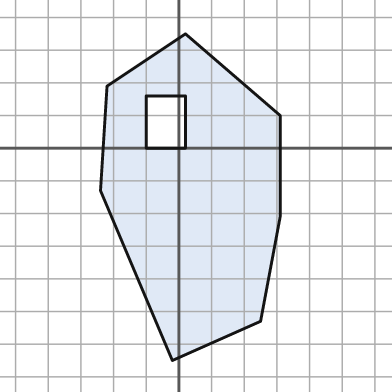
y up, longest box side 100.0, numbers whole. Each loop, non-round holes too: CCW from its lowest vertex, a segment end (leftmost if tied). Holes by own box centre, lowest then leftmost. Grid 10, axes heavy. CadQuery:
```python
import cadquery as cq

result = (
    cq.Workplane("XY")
    .moveTo(-2.0, -65.0)
    .lineTo(25.0, -53.0)
    .lineTo(31.0, -21.0)
    .lineTo(31.0, 10.0)
    .lineTo(2.0, 35.0)
    .lineTo(-22.0, 19.0)
    .lineTo(-24.0, -13.0)
    .close()
    .moveTo(-10.0, 0.0)
    .lineTo(2.0, 0.0)
    .lineTo(2.0, 16.0)
    .lineTo(-10.0, 16.0)
    .close()
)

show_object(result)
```